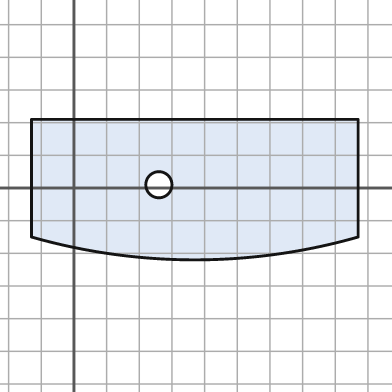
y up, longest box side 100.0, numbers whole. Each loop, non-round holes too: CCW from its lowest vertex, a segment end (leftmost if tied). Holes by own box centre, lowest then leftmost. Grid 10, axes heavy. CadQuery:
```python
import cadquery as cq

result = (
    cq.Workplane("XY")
    .moveTo(-13.0, -15.0)
    .threePointArc((37.0, -22.0), (87.0, -15.0))
    .lineTo(87.0, 21.0)
    .lineTo(-13.0, 21.0)
    .close()
    .moveTo(26.0, 1.0)
    .circle(4.0)
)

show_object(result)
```